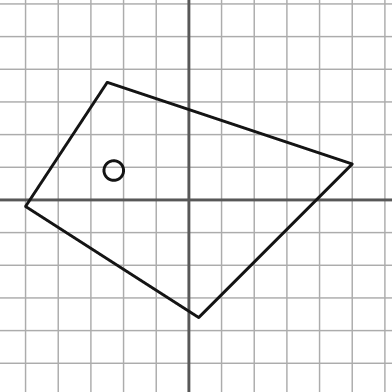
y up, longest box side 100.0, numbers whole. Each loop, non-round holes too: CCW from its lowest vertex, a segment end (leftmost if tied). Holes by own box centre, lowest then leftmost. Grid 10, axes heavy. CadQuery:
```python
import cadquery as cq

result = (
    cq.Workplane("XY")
    .moveTo(3.0, -36.0)
    .lineTo(50.0, 11.0)
    .lineTo(-25.0, 36.0)
    .lineTo(-50.0, -2.0)
    .close()
    .moveTo(-23.0, 9.0)
    .circle(3.0)
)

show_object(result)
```